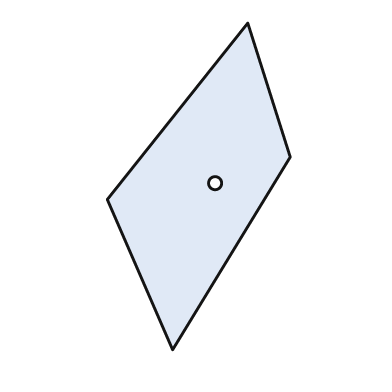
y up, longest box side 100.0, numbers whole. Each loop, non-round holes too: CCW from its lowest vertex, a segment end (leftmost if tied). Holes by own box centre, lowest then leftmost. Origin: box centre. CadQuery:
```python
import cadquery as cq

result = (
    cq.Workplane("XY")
    .moveTo(-8.0, -50.0)
    .lineTo(28.0, 9.0)
    .lineTo(15.0, 50.0)
    .lineTo(-28.0, -4.0)
    .close()
    .moveTo(5.0, 1.0)
    .circle(2.0)
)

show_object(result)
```